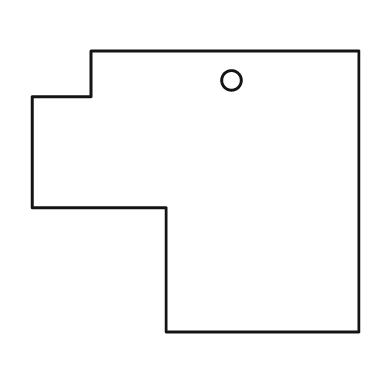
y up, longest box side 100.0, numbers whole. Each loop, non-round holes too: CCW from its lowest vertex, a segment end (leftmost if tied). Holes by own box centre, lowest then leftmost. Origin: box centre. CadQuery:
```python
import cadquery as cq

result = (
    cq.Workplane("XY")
    .moveTo(-9.0, -43.0)
    .lineTo(50.0, -43.0)
    .lineTo(50.0, 43.0)
    .lineTo(-32.0, 43.0)
    .lineTo(-32.0, 29.0)
    .lineTo(-50.0, 29.0)
    .lineTo(-50.0, -5.0)
    .lineTo(-9.0, -5.0)
    .close()
    .moveTo(11.0, 34.0)
    .circle(3.0)
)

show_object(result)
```